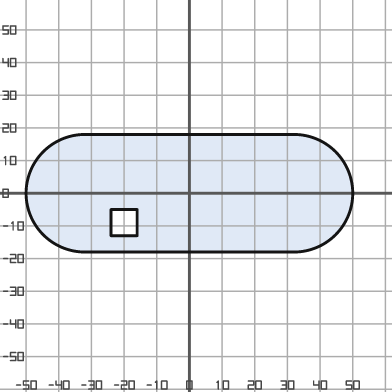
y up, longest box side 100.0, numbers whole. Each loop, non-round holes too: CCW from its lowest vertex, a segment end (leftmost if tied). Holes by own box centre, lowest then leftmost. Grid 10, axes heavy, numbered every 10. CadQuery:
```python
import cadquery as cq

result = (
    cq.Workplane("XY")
    .moveTo(-32.0, -18.0)
    .lineTo(32.0, -18.0)
    .threePointArc((50.0, 0.0), (32.0, 18.0))
    .lineTo(-32.0, 18.0)
    .threePointArc((-50.0, 0.0), (-32.0, -18.0))
    .close()
    .moveTo(-24.0, -13.0)
    .lineTo(-16.0, -13.0)
    .lineTo(-16.0, -5.0)
    .lineTo(-24.0, -5.0)
    .close()
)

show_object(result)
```